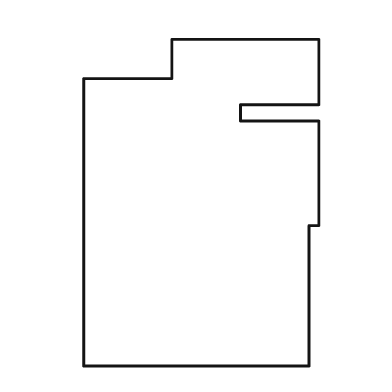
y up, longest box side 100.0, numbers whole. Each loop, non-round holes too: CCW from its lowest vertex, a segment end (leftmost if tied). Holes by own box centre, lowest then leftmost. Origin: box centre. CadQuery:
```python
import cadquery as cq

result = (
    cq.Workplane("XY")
    .moveTo(-36.0, -50.0)
    .lineTo(33.0, -50.0)
    .lineTo(33.0, -7.0)
    .lineTo(36.0, -7.0)
    .lineTo(36.0, 25.0)
    .lineTo(12.0, 25.0)
    .lineTo(12.0, 30.0)
    .lineTo(36.0, 30.0)
    .lineTo(36.0, 50.0)
    .lineTo(-9.0, 50.0)
    .lineTo(-9.0, 38.0)
    .lineTo(-36.0, 38.0)
    .close()
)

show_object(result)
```